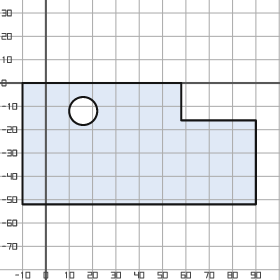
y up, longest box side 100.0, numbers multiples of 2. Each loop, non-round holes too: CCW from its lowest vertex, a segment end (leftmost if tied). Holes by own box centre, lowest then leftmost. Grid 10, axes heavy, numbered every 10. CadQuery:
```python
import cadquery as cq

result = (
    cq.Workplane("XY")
    .moveTo(-10.0, -52.0)
    .lineTo(90.0, -52.0)
    .lineTo(90.0, -16.0)
    .lineTo(58.0, -16.0)
    .lineTo(58.0, 0.0)
    .lineTo(-10.0, 0.0)
    .close()
    .moveTo(16.0, -12.0)
    .circle(6.0)
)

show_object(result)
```